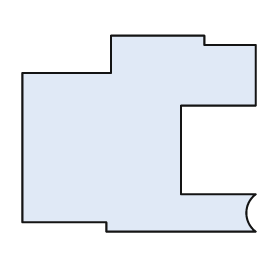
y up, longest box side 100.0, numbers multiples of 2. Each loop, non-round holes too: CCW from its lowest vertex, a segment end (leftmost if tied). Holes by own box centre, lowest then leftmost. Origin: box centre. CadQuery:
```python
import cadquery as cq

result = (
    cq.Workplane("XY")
    .moveTo(-14.0, -42.0)
    .lineTo(50.0, -42.0)
    .threePointArc((46.0, -34.0), (50.0, -26.0))
    .lineTo(18.0, -26.0)
    .lineTo(18.0, 12.0)
    .lineTo(50.0, 12.0)
    .lineTo(50.0, 38.0)
    .lineTo(28.0, 38.0)
    .lineTo(28.0, 42.0)
    .lineTo(-12.0, 42.0)
    .lineTo(-12.0, 26.0)
    .lineTo(-50.0, 26.0)
    .lineTo(-50.0, -38.0)
    .lineTo(-14.0, -38.0)
    .close()
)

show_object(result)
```